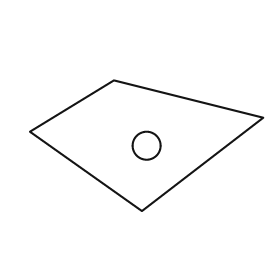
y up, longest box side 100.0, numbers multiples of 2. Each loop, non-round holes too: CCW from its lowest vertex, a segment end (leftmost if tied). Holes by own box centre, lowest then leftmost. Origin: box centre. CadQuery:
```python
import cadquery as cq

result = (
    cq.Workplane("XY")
    .moveTo(-2.0, -28.0)
    .lineTo(50.0, 12.0)
    .lineTo(-14.0, 28.0)
    .lineTo(-50.0, 6.0)
    .close()
    .moveTo(0.0, 0.0)
    .circle(6.0)
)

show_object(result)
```